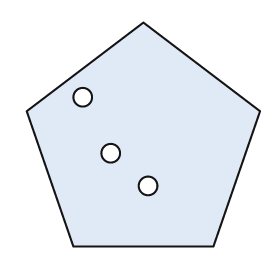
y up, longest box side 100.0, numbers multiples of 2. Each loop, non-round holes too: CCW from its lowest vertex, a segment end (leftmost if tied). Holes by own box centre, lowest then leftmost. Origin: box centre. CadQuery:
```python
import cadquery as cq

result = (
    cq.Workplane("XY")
    .moveTo(-30.0, -48.0)
    .lineTo(30.0, -48.0)
    .lineTo(50.0, 10.0)
    .lineTo(0.0, 48.0)
    .lineTo(-50.0, 10.0)
    .close()
    .moveTo(2.0, -22.0)
    .circle(4.0)
    .moveTo(-14.0, -8.0)
    .circle(4.0)
    .moveTo(-26.0, 16.0)
    .circle(4.0)
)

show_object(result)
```